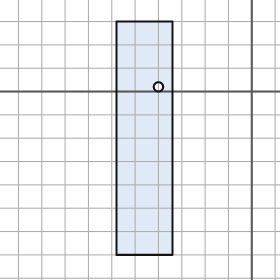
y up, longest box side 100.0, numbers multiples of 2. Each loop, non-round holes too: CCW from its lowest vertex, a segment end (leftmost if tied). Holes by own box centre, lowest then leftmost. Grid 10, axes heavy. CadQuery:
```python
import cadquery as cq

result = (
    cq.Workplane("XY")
    .moveTo(-58.0, -70.0)
    .lineTo(-34.0, -70.0)
    .lineTo(-34.0, 30.0)
    .lineTo(-58.0, 30.0)
    .close()
    .moveTo(-40.0, 2.0)
    .circle(2.0)
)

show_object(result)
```